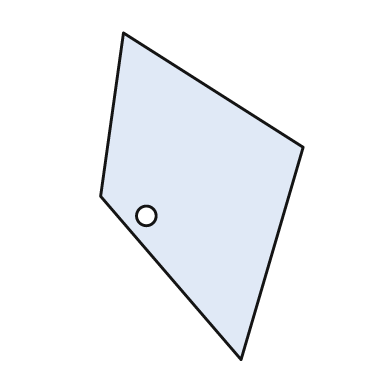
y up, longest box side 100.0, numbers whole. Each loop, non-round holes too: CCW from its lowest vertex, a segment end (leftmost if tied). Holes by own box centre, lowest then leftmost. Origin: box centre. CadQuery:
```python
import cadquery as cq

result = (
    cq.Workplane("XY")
    .moveTo(12.0, -50.0)
    .lineTo(31.0, 15.0)
    .lineTo(-24.0, 50.0)
    .lineTo(-31.0, 0.0)
    .close()
    .moveTo(-17.0, -6.0)
    .circle(3.0)
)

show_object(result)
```